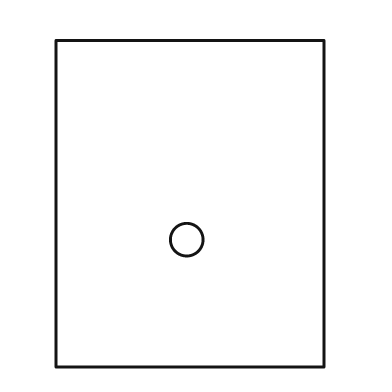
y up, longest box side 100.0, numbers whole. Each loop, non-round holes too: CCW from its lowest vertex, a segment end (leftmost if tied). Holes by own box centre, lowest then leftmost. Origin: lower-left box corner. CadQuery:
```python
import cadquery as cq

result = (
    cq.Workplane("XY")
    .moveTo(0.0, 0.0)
    .lineTo(82.0, 0.0)
    .lineTo(82.0, 100.0)
    .lineTo(0.0, 100.0)
    .close()
    .moveTo(40.0, 39.0)
    .circle(5.0)
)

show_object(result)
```